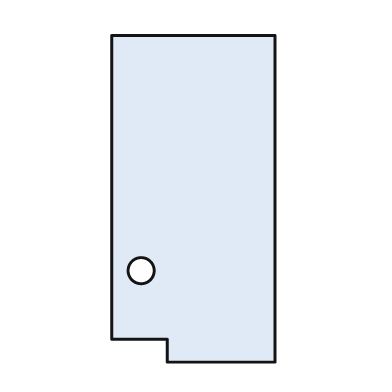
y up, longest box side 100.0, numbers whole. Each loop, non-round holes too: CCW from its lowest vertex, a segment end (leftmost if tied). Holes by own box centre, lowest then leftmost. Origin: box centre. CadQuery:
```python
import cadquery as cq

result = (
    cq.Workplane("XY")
    .moveTo(-8.0, -50.0)
    .lineTo(25.0, -50.0)
    .lineTo(25.0, 50.0)
    .lineTo(-25.0, 50.0)
    .lineTo(-25.0, -43.0)
    .lineTo(-8.0, -43.0)
    .close()
    .moveTo(-16.0, -22.0)
    .circle(4.0)
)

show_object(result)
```